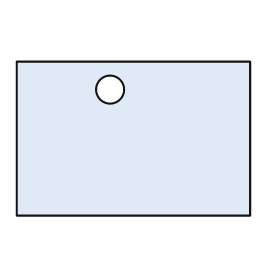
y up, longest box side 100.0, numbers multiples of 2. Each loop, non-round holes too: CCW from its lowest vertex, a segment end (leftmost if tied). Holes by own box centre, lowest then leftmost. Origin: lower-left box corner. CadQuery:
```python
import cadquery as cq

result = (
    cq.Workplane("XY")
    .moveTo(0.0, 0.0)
    .lineTo(100.0, 0.0)
    .lineTo(100.0, 66.0)
    .lineTo(0.0, 66.0)
    .close()
    .moveTo(40.0, 54.0)
    .circle(6.0)
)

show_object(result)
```